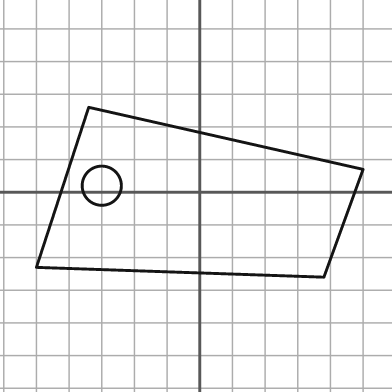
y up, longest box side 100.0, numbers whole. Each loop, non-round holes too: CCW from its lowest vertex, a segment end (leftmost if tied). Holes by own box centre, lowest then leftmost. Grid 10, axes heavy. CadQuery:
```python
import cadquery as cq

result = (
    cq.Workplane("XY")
    .moveTo(38.0, -26.0)
    .lineTo(50.0, 7.0)
    .lineTo(-34.0, 26.0)
    .lineTo(-50.0, -23.0)
    .close()
    .moveTo(-30.0, 2.0)
    .circle(6.0)
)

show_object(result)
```